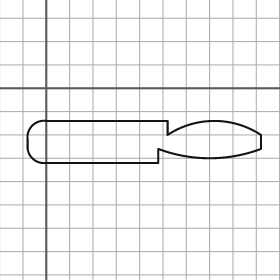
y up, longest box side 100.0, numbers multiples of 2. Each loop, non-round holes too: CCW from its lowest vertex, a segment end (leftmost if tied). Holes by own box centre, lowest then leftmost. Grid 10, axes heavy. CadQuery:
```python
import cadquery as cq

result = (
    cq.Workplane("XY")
    .moveTo(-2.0, -32.0)
    .lineTo(48.0, -32.0)
    .lineTo(48.0, -26.0)
    .threePointArc((70.0, -30.0), (92.0, -26.0))
    .lineTo(92.0, -20.0)
    .threePointArc((72.0, -14.0), (52.0, -20.0))
    .lineTo(52.0, -14.0)
    .lineTo(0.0, -14.0)
    .threePointArc((-6.0, -16.0), (-8.0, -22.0))
    .lineTo(-8.0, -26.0)
    .threePointArc((-6.0, -30.0), (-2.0, -32.0))
    .close()
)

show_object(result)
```